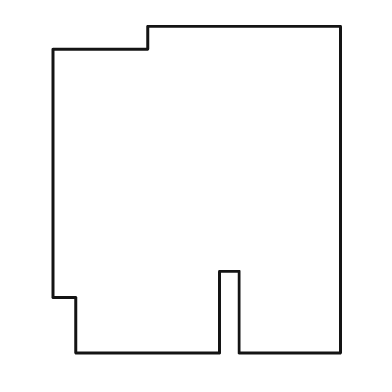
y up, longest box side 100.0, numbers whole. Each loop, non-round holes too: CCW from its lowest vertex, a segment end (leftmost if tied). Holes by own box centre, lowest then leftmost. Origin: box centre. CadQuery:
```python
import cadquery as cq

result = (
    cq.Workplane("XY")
    .moveTo(-37.0, -50.0)
    .lineTo(7.0, -50.0)
    .lineTo(7.0, -25.0)
    .lineTo(13.0, -25.0)
    .lineTo(13.0, -50.0)
    .lineTo(44.0, -50.0)
    .lineTo(44.0, 50.0)
    .lineTo(-15.0, 50.0)
    .lineTo(-15.0, 43.0)
    .lineTo(-44.0, 43.0)
    .lineTo(-44.0, -33.0)
    .lineTo(-37.0, -33.0)
    .close()
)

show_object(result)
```